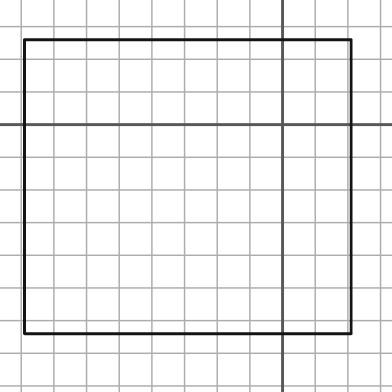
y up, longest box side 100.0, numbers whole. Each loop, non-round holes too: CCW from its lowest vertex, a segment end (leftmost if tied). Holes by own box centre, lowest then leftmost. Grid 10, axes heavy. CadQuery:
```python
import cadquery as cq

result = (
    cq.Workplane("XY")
    .moveTo(-79.0, -64.0)
    .lineTo(21.0, -64.0)
    .lineTo(21.0, 26.0)
    .lineTo(-79.0, 26.0)
    .close()
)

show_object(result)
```